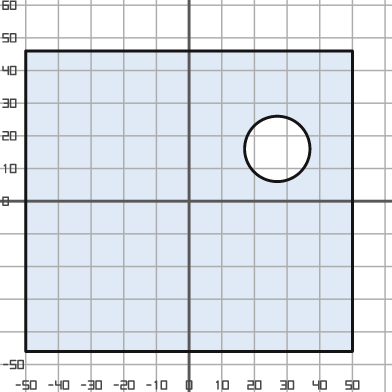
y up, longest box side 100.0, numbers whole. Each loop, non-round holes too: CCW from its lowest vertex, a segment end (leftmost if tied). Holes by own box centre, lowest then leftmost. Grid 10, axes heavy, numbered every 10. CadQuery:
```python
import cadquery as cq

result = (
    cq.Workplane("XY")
    .moveTo(-50.0, -46.0)
    .lineTo(50.0, -46.0)
    .lineTo(50.0, 46.0)
    .lineTo(-50.0, 46.0)
    .close()
    .moveTo(27.0, 16.0)
    .circle(10.0)
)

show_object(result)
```